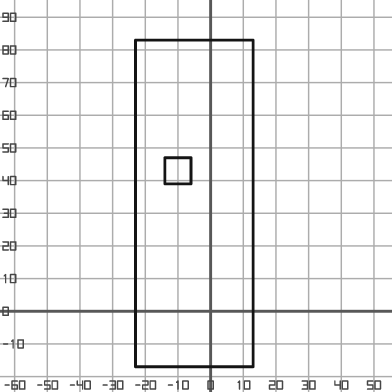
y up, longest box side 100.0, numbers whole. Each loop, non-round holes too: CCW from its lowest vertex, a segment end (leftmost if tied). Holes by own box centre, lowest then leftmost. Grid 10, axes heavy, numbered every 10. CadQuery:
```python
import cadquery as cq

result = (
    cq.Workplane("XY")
    .moveTo(-23.0, -17.0)
    .lineTo(13.0, -17.0)
    .lineTo(13.0, 83.0)
    .lineTo(-23.0, 83.0)
    .close()
    .moveTo(-14.0, 39.0)
    .lineTo(-6.0, 39.0)
    .lineTo(-6.0, 47.0)
    .lineTo(-14.0, 47.0)
    .close()
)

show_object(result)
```